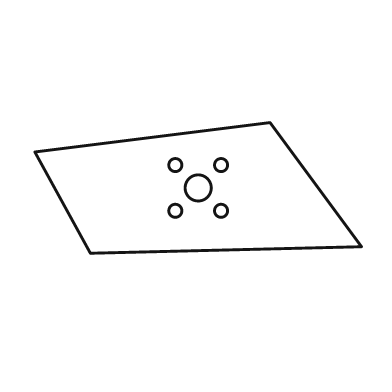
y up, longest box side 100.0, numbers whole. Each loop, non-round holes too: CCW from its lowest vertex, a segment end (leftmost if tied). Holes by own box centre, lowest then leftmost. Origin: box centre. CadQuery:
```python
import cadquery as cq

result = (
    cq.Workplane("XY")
    .moveTo(-33.0, -20.0)
    .lineTo(50.0, -18.0)
    .lineTo(22.0, 20.0)
    .lineTo(-50.0, 11.0)
    .close()
    .moveTo(-7.0, -7.0)
    .circle(2.0)
    .moveTo(7.0, -7.0)
    .circle(2.0)
    .moveTo(0.0, 0.0)
    .circle(4.0)
    .moveTo(-7.0, 7.0)
    .circle(2.0)
    .moveTo(7.0, 7.0)
    .circle(2.0)
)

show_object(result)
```